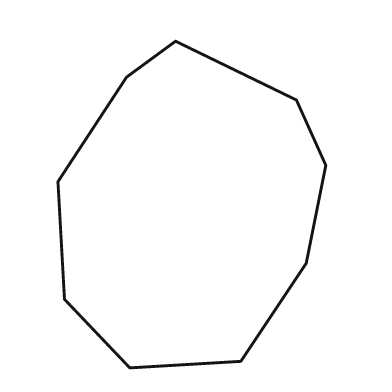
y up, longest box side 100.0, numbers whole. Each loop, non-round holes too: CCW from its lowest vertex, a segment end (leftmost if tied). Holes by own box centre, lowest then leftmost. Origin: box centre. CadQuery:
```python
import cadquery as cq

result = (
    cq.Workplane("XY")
    .moveTo(-19.0, -50.0)
    .lineTo(15.0, -48.0)
    .lineTo(35.0, -18.0)
    .lineTo(41.0, 12.0)
    .lineTo(32.0, 32.0)
    .lineTo(-5.0, 50.0)
    .lineTo(-20.0, 39.0)
    .lineTo(-41.0, 7.0)
    .lineTo(-39.0, -29.0)
    .close()
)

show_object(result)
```